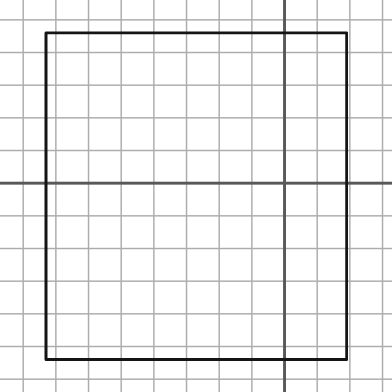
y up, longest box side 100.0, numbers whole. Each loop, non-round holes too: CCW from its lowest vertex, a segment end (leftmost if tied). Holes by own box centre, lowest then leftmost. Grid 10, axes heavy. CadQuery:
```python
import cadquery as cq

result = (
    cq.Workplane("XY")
    .moveTo(-73.0, -54.0)
    .lineTo(19.0, -54.0)
    .lineTo(19.0, 46.0)
    .lineTo(-73.0, 46.0)
    .close()
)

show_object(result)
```